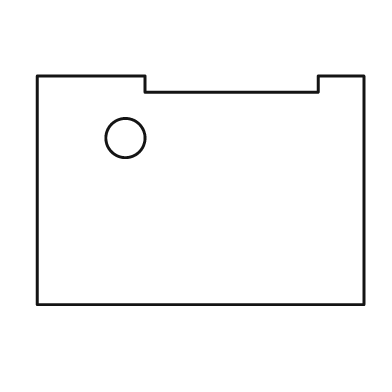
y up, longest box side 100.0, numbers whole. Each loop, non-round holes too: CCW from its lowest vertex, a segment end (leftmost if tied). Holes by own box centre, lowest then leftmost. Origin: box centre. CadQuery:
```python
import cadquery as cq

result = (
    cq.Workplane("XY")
    .moveTo(-50.0, -35.0)
    .lineTo(50.0, -35.0)
    .lineTo(50.0, 35.0)
    .lineTo(36.0, 35.0)
    .lineTo(36.0, 30.0)
    .lineTo(-17.0, 30.0)
    .lineTo(-17.0, 35.0)
    .lineTo(-50.0, 35.0)
    .close()
    .moveTo(-23.0, 16.0)
    .circle(6.0)
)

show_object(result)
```